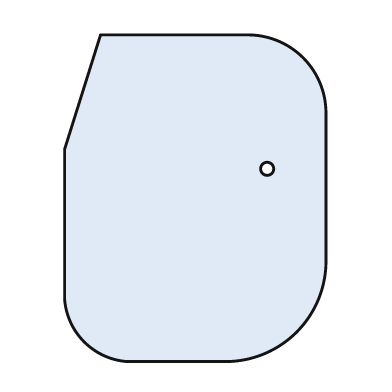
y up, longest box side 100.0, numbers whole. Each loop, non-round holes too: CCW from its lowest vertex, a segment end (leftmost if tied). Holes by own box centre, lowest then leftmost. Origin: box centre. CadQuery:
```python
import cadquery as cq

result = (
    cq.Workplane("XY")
    .moveTo(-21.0, -50.0)
    .lineTo(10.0, -50.0)
    .threePointArc((31.0, -41.0), (40.0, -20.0))
    .lineTo(40.0, 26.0)
    .threePointArc((33.0, 43.0), (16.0, 50.0))
    .lineTo(-29.0, 50.0)
    .lineTo(-40.0, 15.0)
    .lineTo(-40.0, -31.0)
    .threePointArc((-34.0, -44.0), (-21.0, -50.0))
    .close()
    .moveTo(22.0, 9.0)
    .circle(2.0)
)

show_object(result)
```